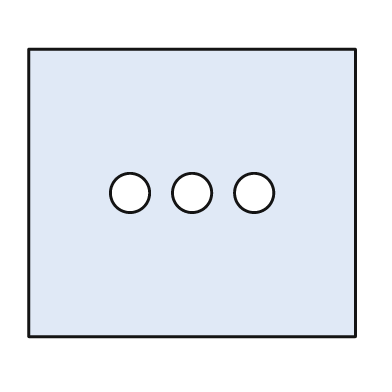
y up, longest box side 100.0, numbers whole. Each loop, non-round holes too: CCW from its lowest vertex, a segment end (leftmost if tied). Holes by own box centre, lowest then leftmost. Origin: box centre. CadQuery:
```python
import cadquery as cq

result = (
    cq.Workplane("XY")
    .moveTo(-50.0, -44.0)
    .lineTo(50.0, -44.0)
    .lineTo(50.0, 44.0)
    .lineTo(-50.0, 44.0)
    .close()
    .moveTo(-19.0, 0.0)
    .circle(6.0)
    .moveTo(0.0, 0.0)
    .circle(6.0)
    .moveTo(19.0, 0.0)
    .circle(6.0)
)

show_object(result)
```